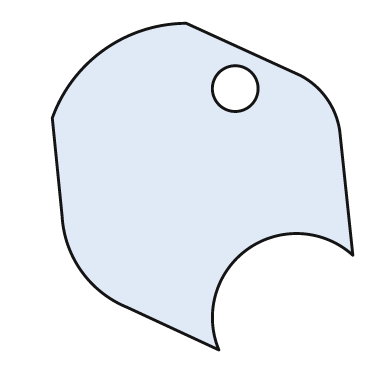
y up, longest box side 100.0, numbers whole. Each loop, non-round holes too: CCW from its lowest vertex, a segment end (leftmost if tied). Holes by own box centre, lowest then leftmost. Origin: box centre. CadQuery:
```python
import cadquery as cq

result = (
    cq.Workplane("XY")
    .moveTo(5.0, -50.0)
    .threePointArc((14.0, -19.0), (46.0, -21.0))
    .lineTo(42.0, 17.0)
    .threePointArc((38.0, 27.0), (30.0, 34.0))
    .lineTo(-5.0, 50.0)
    .threePointArc((-30.0, 42.0), (-46.0, 21.0))
    .lineTo(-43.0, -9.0)
    .threePointArc((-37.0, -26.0), (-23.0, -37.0))
    .close()
    .moveTo(10.0, 30.0)
    .circle(7.0)
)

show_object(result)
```